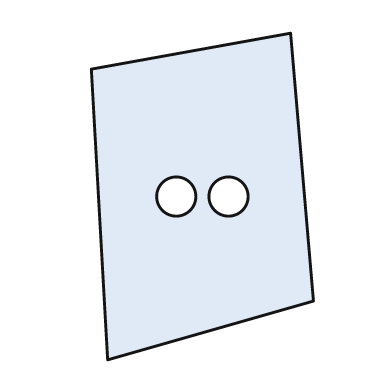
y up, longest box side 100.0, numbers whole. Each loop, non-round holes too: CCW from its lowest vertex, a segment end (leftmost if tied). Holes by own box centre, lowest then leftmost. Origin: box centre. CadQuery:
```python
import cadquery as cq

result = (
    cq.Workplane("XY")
    .moveTo(-29.0, -50.0)
    .lineTo(34.0, -32.0)
    .lineTo(27.0, 50.0)
    .lineTo(-34.0, 39.0)
    .close()
    .moveTo(-8.0, 0.0)
    .circle(6.0)
    .moveTo(8.0, 0.0)
    .circle(6.0)
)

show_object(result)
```